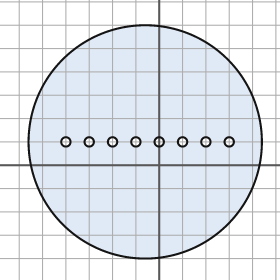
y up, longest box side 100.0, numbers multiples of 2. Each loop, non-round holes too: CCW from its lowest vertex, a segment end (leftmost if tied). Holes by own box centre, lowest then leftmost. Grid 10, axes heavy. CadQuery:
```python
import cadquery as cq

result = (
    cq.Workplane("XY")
    .moveTo(-6.0, 10.0)
    .circle(50.0)
    .moveTo(-40.0, 10.0)
    .circle(2.0)
    .moveTo(-30.0, 10.0)
    .circle(2.0)
    .moveTo(-20.0, 10.0)
    .circle(2.0)
    .moveTo(-10.0, 10.0)
    .circle(2.0)
    .moveTo(0.0, 10.0)
    .circle(2.0)
    .moveTo(10.0, 10.0)
    .circle(2.0)
    .moveTo(20.0, 10.0)
    .circle(2.0)
    .moveTo(30.0, 10.0)
    .circle(2.0)
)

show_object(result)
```